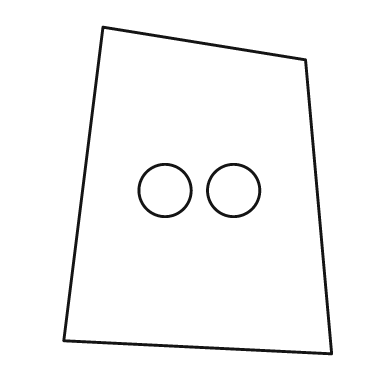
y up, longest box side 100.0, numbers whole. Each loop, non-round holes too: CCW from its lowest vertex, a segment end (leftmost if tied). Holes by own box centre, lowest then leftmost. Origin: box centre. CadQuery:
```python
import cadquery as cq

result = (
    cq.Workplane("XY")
    .moveTo(41.0, -50.0)
    .lineTo(33.0, 40.0)
    .lineTo(-29.0, 50.0)
    .lineTo(-41.0, -46.0)
    .close()
    .moveTo(-10.0, 0.0)
    .circle(8.0)
    .moveTo(11.0, 0.0)
    .circle(8.0)
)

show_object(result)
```